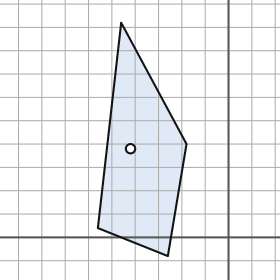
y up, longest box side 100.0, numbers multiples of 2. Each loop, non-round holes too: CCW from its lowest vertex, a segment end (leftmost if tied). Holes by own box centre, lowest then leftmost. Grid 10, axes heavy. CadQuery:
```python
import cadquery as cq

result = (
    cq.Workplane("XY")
    .moveTo(-26.0, -8.0)
    .lineTo(-18.0, 40.0)
    .lineTo(-46.0, 92.0)
    .lineTo(-56.0, 4.0)
    .close()
    .moveTo(-42.0, 38.0)
    .circle(2.0)
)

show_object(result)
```